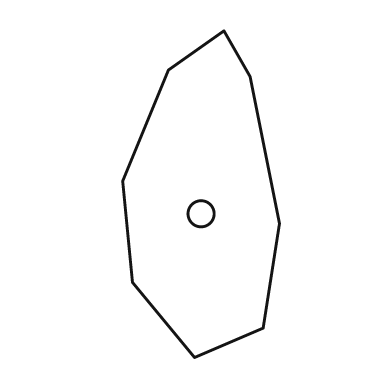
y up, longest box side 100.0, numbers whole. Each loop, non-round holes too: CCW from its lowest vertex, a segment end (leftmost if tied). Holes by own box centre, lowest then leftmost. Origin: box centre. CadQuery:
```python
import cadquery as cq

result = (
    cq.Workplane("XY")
    .moveTo(-2.0, -50.0)
    .lineTo(19.0, -41.0)
    .lineTo(24.0, -9.0)
    .lineTo(15.0, 36.0)
    .lineTo(7.0, 50.0)
    .lineTo(-10.0, 38.0)
    .lineTo(-24.0, 4.0)
    .lineTo(-21.0, -27.0)
    .close()
    .moveTo(0.0, -6.0)
    .circle(4.0)
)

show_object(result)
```